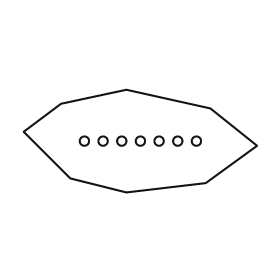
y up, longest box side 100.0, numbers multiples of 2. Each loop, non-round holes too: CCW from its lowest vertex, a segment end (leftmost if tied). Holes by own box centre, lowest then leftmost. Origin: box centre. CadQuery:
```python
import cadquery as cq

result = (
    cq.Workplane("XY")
    .moveTo(-6.0, -22.0)
    .lineTo(28.0, -18.0)
    .lineTo(50.0, -2.0)
    .lineTo(30.0, 14.0)
    .lineTo(-6.0, 22.0)
    .lineTo(-34.0, 16.0)
    .lineTo(-50.0, 4.0)
    .lineTo(-30.0, -16.0)
    .close()
    .moveTo(-24.0, 0.0)
    .circle(2.0)
    .moveTo(-16.0, 0.0)
    .circle(2.0)
    .moveTo(-8.0, 0.0)
    .circle(2.0)
    .moveTo(0.0, 0.0)
    .circle(2.0)
    .moveTo(8.0, 0.0)
    .circle(2.0)
    .moveTo(16.0, 0.0)
    .circle(2.0)
    .moveTo(24.0, 0.0)
    .circle(2.0)
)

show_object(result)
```